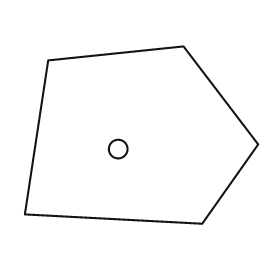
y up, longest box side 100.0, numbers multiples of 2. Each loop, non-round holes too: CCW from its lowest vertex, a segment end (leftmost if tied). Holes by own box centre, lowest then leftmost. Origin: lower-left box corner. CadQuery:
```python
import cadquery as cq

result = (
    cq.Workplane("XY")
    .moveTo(76.0, 0.0)
    .lineTo(100.0, 34.0)
    .lineTo(68.0, 76.0)
    .lineTo(10.0, 70.0)
    .lineTo(0.0, 4.0)
    .close()
    .moveTo(40.0, 32.0)
    .circle(4.0)
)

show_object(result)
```